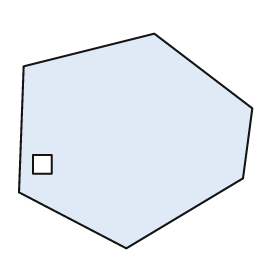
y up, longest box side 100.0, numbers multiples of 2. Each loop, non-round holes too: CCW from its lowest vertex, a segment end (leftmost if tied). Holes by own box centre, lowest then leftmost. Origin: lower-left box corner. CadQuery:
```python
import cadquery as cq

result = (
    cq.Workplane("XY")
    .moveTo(46.0, 0.0)
    .lineTo(96.0, 30.0)
    .lineTo(100.0, 60.0)
    .lineTo(58.0, 92.0)
    .lineTo(2.0, 78.0)
    .lineTo(0.0, 24.0)
    .close()
    .moveTo(6.0, 32.0)
    .lineTo(14.0, 32.0)
    .lineTo(14.0, 40.0)
    .lineTo(6.0, 40.0)
    .close()
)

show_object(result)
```